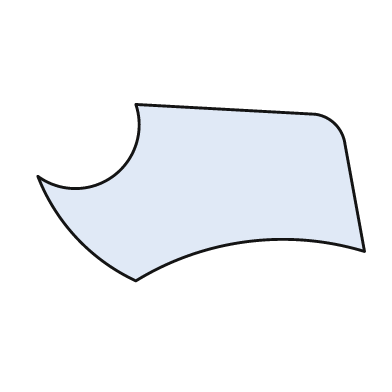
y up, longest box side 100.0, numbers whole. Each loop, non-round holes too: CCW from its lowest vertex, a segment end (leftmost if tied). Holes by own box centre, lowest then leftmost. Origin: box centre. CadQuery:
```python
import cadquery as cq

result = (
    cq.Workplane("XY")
    .moveTo(-20.0, -27.0)
    .threePointArc((14.0, -15.0), (50.0, -18.0))
    .lineTo(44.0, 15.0)
    .threePointArc((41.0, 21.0), (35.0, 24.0))
    .lineTo(-20.0, 27.0)
    .threePointArc((-27.0, 5.0), (-50.0, 5.0))
    .threePointArc((-38.0, -14.0), (-20.0, -27.0))
    .close()
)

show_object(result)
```